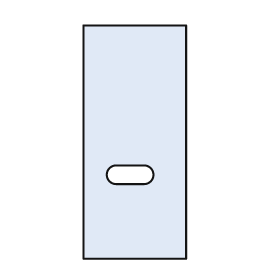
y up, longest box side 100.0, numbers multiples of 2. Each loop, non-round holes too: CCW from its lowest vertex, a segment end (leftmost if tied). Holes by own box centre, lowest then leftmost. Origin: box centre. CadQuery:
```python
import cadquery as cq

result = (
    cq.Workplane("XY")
    .moveTo(-22.0, -50.0)
    .lineTo(22.0, -50.0)
    .lineTo(22.0, 50.0)
    .lineTo(-22.0, 50.0)
    .close()
    .moveTo(-8.0, -18.0)
    .lineTo(4.0, -18.0)
    .threePointArc((8.0, -14.0), (4.0, -10.0))
    .lineTo(-8.0, -10.0)
    .threePointArc((-12.0, -14.0), (-8.0, -18.0))
    .close()
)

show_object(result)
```